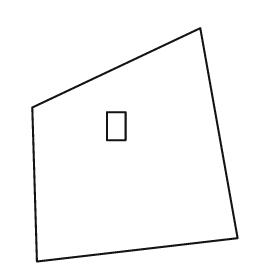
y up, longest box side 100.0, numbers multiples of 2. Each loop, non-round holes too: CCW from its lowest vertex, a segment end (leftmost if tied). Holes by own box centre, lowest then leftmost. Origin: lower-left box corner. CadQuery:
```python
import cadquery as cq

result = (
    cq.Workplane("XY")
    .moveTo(2.0, 0.0)
    .lineTo(88.0, 10.0)
    .lineTo(72.0, 100.0)
    .lineTo(0.0, 66.0)
    .close()
    .moveTo(32.0, 52.0)
    .lineTo(40.0, 52.0)
    .lineTo(40.0, 64.0)
    .lineTo(32.0, 64.0)
    .close()
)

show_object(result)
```